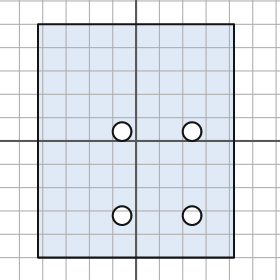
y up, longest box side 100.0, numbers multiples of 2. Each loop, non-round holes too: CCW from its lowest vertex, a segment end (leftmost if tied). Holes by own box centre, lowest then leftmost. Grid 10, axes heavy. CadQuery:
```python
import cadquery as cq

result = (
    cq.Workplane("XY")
    .moveTo(-42.0, -50.0)
    .lineTo(42.0, -50.0)
    .lineTo(42.0, 50.0)
    .lineTo(-42.0, 50.0)
    .close()
    .moveTo(-6.0, -32.0)
    .circle(4.0)
    .moveTo(24.0, -32.0)
    .circle(4.0)
    .moveTo(-6.0, 4.0)
    .circle(4.0)
    .moveTo(24.0, 4.0)
    .circle(4.0)
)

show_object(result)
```